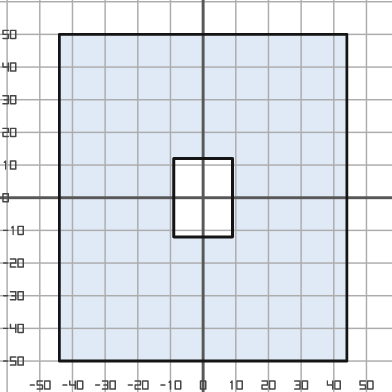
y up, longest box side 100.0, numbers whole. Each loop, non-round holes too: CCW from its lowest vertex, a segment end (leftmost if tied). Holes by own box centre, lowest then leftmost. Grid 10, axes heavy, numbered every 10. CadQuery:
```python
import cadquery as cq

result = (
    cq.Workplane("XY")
    .moveTo(-44.0, -50.0)
    .lineTo(44.0, -50.0)
    .lineTo(44.0, 50.0)
    .lineTo(-44.0, 50.0)
    .close()
    .moveTo(-9.0, -12.0)
    .lineTo(9.0, -12.0)
    .lineTo(9.0, 12.0)
    .lineTo(-9.0, 12.0)
    .close()
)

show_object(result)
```